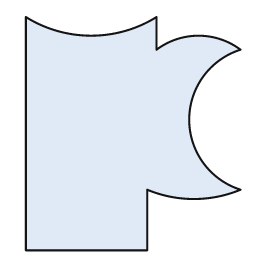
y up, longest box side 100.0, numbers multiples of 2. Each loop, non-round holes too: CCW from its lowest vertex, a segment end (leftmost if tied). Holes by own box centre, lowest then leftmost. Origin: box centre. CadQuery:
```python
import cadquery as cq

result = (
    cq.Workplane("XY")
    .moveTo(-46.0, -50.0)
    .lineTo(6.0, -50.0)
    .lineTo(6.0, -24.0)
    .threePointArc((26.0, -28.0), (46.0, -24.0))
    .threePointArc((24.0, 6.0), (46.0, 36.0))
    .threePointArc((28.0, 42.0), (10.0, 36.0))
    .lineTo(10.0, 50.0)
    .threePointArc((-18.0, 42.0), (-46.0, 50.0))
    .close()
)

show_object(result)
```